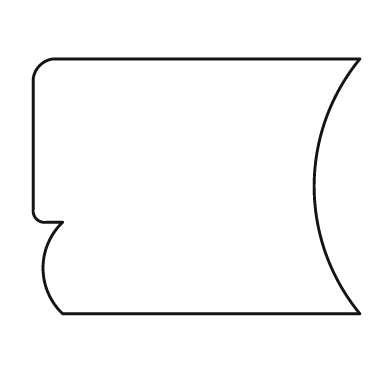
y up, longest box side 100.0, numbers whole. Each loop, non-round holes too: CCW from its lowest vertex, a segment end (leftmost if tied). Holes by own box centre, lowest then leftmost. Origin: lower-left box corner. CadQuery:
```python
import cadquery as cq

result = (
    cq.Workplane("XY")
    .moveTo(9.0, 0.0)
    .lineTo(100.0, 0.0)
    .threePointArc((86.0, 39.0), (100.0, 78.0))
    .lineTo(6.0, 78.0)
    .threePointArc((2.0, 76.0), (0.0, 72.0))
    .lineTo(0.0, 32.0)
    .threePointArc((1.0, 29.0), (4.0, 28.0))
    .lineTo(9.0, 28.0)
    .threePointArc((3.0, 14.0), (9.0, 0.0))
    .close()
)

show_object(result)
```